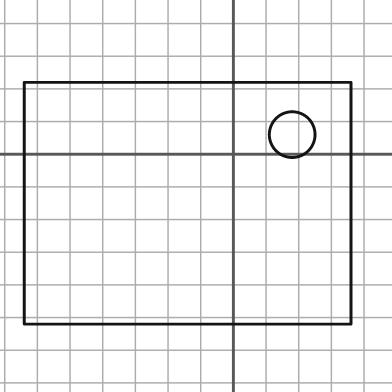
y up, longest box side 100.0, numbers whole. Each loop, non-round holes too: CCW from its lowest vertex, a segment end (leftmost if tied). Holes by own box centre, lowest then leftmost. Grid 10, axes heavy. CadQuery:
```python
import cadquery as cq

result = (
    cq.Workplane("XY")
    .moveTo(-64.0, -52.0)
    .lineTo(36.0, -52.0)
    .lineTo(36.0, 22.0)
    .lineTo(-64.0, 22.0)
    .close()
    .moveTo(18.0, 6.0)
    .circle(7.0)
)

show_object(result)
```